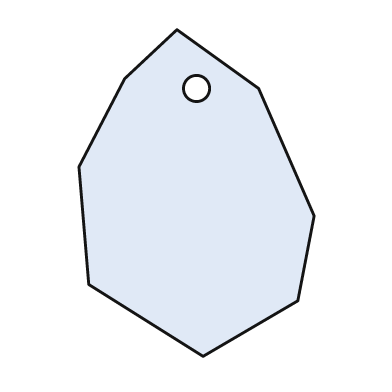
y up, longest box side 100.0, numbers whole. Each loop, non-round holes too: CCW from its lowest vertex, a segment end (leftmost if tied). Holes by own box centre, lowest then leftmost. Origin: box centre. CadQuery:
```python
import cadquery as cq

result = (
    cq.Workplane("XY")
    .moveTo(2.0, -50.0)
    .lineTo(31.0, -33.0)
    .lineTo(36.0, -7.0)
    .lineTo(19.0, 32.0)
    .lineTo(-6.0, 50.0)
    .lineTo(-22.0, 35.0)
    .lineTo(-36.0, 8.0)
    .lineTo(-33.0, -28.0)
    .close()
    .moveTo(0.0, 32.0)
    .circle(4.0)
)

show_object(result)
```